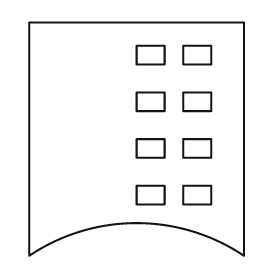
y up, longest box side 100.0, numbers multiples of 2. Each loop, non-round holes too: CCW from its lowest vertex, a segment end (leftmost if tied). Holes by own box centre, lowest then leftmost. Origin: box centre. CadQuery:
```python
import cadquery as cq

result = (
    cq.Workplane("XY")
    .moveTo(-46.0, -50.0)
    .threePointArc((0.0, -36.0), (46.0, -50.0))
    .lineTo(46.0, 50.0)
    .lineTo(-46.0, 50.0)
    .close()
    .moveTo(0.0, -28.0)
    .lineTo(12.0, -28.0)
    .lineTo(12.0, -20.0)
    .lineTo(0.0, -20.0)
    .close()
    .moveTo(20.0, -28.0)
    .lineTo(32.0, -28.0)
    .lineTo(32.0, -20.0)
    .lineTo(20.0, -20.0)
    .close()
    .moveTo(0.0, -8.0)
    .lineTo(12.0, -8.0)
    .lineTo(12.0, 0.0)
    .lineTo(0.0, 0.0)
    .close()
    .moveTo(20.0, -8.0)
    .lineTo(32.0, -8.0)
    .lineTo(32.0, 0.0)
    .lineTo(20.0, 0.0)
    .close()
    .moveTo(0.0, 12.0)
    .lineTo(12.0, 12.0)
    .lineTo(12.0, 20.0)
    .lineTo(0.0, 20.0)
    .close()
    .moveTo(20.0, 12.0)
    .lineTo(32.0, 12.0)
    .lineTo(32.0, 20.0)
    .lineTo(20.0, 20.0)
    .close()
    .moveTo(0.0, 32.0)
    .lineTo(12.0, 32.0)
    .lineTo(12.0, 40.0)
    .lineTo(0.0, 40.0)
    .close()
    .moveTo(20.0, 32.0)
    .lineTo(32.0, 32.0)
    .lineTo(32.0, 40.0)
    .lineTo(20.0, 40.0)
    .close()
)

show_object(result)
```